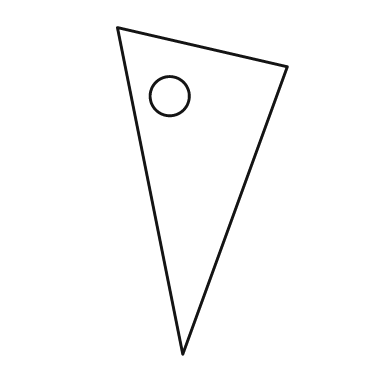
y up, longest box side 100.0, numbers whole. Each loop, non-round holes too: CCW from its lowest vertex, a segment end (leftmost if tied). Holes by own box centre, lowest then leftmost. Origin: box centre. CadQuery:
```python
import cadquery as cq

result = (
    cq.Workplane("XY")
    .moveTo(-6.0, -50.0)
    .lineTo(26.0, 38.0)
    .lineTo(-26.0, 50.0)
    .close()
    .moveTo(-10.0, 29.0)
    .circle(6.0)
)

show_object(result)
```